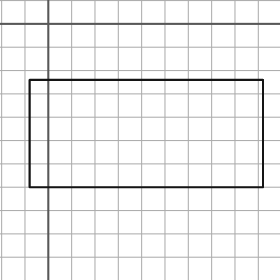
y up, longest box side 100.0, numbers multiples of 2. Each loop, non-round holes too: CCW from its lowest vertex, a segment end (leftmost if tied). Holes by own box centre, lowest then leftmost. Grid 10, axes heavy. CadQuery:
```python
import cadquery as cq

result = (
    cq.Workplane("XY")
    .moveTo(-8.0, -70.0)
    .lineTo(92.0, -70.0)
    .lineTo(92.0, -24.0)
    .lineTo(-8.0, -24.0)
    .close()
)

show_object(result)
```